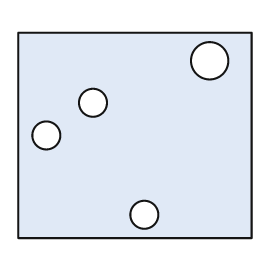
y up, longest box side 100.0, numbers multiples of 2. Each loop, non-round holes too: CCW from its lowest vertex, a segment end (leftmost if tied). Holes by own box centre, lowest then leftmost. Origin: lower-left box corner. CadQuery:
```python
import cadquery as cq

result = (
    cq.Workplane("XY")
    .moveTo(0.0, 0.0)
    .lineTo(100.0, 0.0)
    .lineTo(100.0, 88.0)
    .lineTo(0.0, 88.0)
    .close()
    .moveTo(54.0, 10.0)
    .circle(6.0)
    .moveTo(12.0, 44.0)
    .circle(6.0)
    .moveTo(32.0, 58.0)
    .circle(6.0)
    .moveTo(82.0, 76.0)
    .circle(8.0)
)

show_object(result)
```